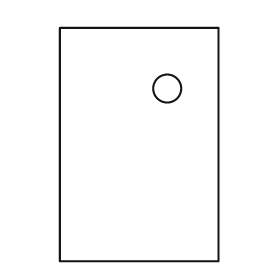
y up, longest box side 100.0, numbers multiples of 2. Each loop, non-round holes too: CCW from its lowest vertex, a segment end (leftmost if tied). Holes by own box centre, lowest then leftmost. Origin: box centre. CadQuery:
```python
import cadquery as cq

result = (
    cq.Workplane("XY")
    .moveTo(-34.0, -50.0)
    .lineTo(34.0, -50.0)
    .lineTo(34.0, 50.0)
    .lineTo(-34.0, 50.0)
    .close()
    .moveTo(12.0, 24.0)
    .circle(6.0)
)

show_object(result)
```